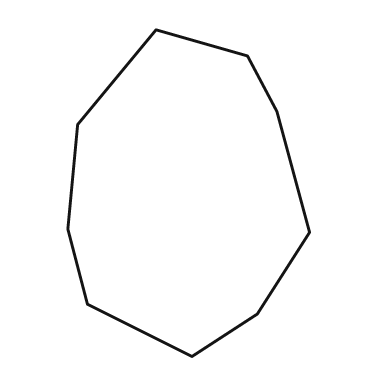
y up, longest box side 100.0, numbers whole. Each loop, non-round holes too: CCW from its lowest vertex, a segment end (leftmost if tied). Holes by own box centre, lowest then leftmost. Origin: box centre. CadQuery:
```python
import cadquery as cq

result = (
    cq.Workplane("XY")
    .moveTo(1.0, -50.0)
    .lineTo(21.0, -37.0)
    .lineTo(37.0, -12.0)
    .lineTo(27.0, 25.0)
    .lineTo(18.0, 42.0)
    .lineTo(-10.0, 50.0)
    .lineTo(-34.0, 21.0)
    .lineTo(-37.0, -11.0)
    .lineTo(-31.0, -34.0)
    .close()
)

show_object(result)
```